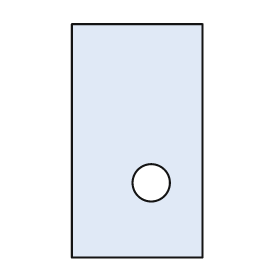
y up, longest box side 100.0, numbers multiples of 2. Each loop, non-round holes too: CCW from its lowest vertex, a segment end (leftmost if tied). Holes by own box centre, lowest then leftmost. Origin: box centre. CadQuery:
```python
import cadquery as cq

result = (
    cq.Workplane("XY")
    .moveTo(-28.0, -50.0)
    .lineTo(28.0, -50.0)
    .lineTo(28.0, 50.0)
    .lineTo(-28.0, 50.0)
    .close()
    .moveTo(6.0, -18.0)
    .circle(8.0)
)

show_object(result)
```